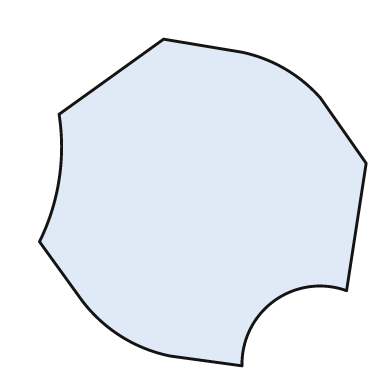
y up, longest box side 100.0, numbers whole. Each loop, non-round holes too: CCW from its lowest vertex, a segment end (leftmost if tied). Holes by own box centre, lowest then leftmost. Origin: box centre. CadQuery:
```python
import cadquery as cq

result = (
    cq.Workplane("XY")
    .moveTo(12.0, -50.0)
    .threePointArc((22.0, -30.0), (44.0, -27.0))
    .lineTo(50.0, 12.0)
    .lineTo(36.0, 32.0)
    .threePointArc((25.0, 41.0), (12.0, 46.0))
    .lineTo(-12.0, 50.0)
    .lineTo(-44.0, 27.0)
    .threePointArc((-44.0, 7.0), (-50.0, -12.0))
    .lineTo(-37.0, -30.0)
    .threePointArc((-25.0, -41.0), (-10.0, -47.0))
    .close()
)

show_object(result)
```